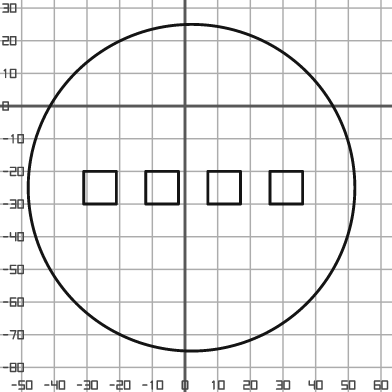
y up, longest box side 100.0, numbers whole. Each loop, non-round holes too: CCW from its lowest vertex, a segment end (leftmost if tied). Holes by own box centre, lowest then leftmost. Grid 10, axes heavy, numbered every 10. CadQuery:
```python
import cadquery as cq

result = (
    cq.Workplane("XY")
    .moveTo(2.0, -25.0)
    .circle(50.0)
    .moveTo(-31.0, -30.0)
    .lineTo(-21.0, -30.0)
    .lineTo(-21.0, -20.0)
    .lineTo(-31.0, -20.0)
    .close()
    .moveTo(-12.0, -30.0)
    .lineTo(-2.0, -30.0)
    .lineTo(-2.0, -20.0)
    .lineTo(-12.0, -20.0)
    .close()
    .moveTo(7.0, -30.0)
    .lineTo(17.0, -30.0)
    .lineTo(17.0, -20.0)
    .lineTo(7.0, -20.0)
    .close()
    .moveTo(26.0, -30.0)
    .lineTo(36.0, -30.0)
    .lineTo(36.0, -20.0)
    .lineTo(26.0, -20.0)
    .close()
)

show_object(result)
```